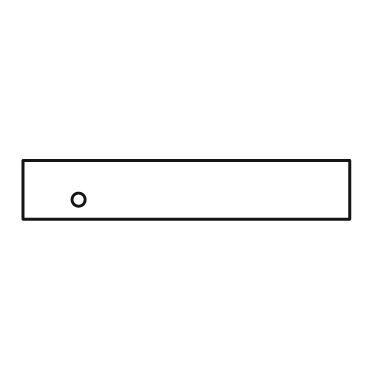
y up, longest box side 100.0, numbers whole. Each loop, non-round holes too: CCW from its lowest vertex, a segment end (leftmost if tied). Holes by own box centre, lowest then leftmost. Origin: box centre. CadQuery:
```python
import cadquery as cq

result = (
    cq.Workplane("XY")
    .moveTo(-50.0, -9.0)
    .lineTo(50.0, -9.0)
    .lineTo(50.0, 9.0)
    .lineTo(-50.0, 9.0)
    .close()
    .moveTo(-33.0, -3.0)
    .circle(2.0)
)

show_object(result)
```